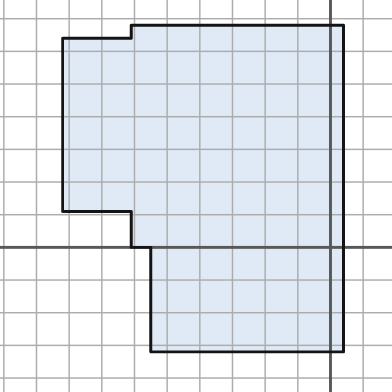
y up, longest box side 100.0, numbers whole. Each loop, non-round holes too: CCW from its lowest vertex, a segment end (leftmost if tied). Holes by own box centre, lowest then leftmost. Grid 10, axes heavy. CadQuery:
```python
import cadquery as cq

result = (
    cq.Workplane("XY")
    .moveTo(-55.0, -32.0)
    .lineTo(4.0, -32.0)
    .lineTo(4.0, 68.0)
    .lineTo(-61.0, 68.0)
    .lineTo(-61.0, 64.0)
    .lineTo(-82.0, 64.0)
    .lineTo(-82.0, 11.0)
    .lineTo(-61.0, 11.0)
    .lineTo(-61.0, 0.0)
    .lineTo(-55.0, 0.0)
    .close()
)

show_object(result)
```